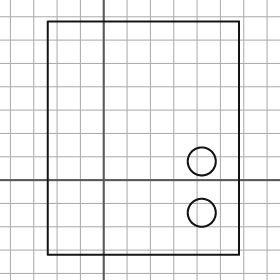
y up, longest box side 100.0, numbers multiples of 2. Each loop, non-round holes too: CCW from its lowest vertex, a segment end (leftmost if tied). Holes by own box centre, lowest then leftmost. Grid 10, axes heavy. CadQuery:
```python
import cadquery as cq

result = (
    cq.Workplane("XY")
    .moveTo(-24.0, -32.0)
    .lineTo(58.0, -32.0)
    .lineTo(58.0, 68.0)
    .lineTo(-24.0, 68.0)
    .close()
    .moveTo(42.0, -14.0)
    .circle(6.0)
    .moveTo(42.0, 8.0)
    .circle(6.0)
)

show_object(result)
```